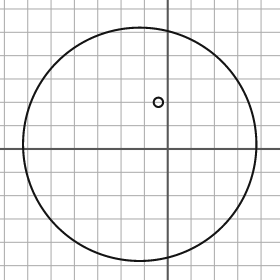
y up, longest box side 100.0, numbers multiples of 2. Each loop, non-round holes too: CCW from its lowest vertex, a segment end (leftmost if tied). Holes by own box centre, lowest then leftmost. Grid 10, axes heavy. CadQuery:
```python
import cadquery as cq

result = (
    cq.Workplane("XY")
    .moveTo(-12.0, 2.0)
    .circle(50.0)
    .moveTo(-4.0, 20.0)
    .circle(2.0)
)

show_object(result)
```